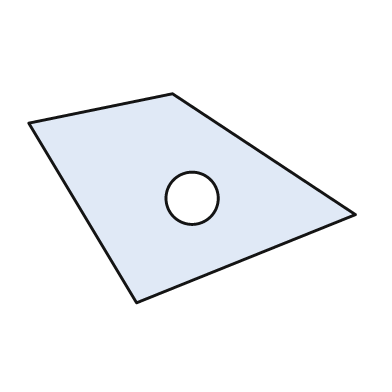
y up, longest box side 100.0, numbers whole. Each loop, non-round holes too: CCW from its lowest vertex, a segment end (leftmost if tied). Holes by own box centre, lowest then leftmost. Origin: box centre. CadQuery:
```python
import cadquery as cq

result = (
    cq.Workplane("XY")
    .moveTo(-17.0, -32.0)
    .lineTo(50.0, -5.0)
    .lineTo(-6.0, 32.0)
    .lineTo(-50.0, 23.0)
    .close()
    .moveTo(0.0, 0.0)
    .circle(8.0)
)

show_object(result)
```